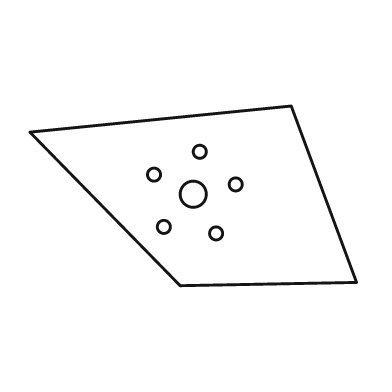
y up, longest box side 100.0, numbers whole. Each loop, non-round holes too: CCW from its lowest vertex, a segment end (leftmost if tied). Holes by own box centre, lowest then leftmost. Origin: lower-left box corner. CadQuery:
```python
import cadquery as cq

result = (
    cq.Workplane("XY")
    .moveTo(46.0, 0.0)
    .lineTo(100.0, 1.0)
    .lineTo(80.0, 55.0)
    .lineTo(0.0, 47.0)
    .close()
    .moveTo(57.0, 16.0)
    .circle(2.0)
    .moveTo(41.0, 18.0)
    .circle(2.0)
    .moveTo(50.0, 28.0)
    .circle(4.0)
    .moveTo(63.0, 31.0)
    .circle(2.0)
    .moveTo(38.0, 34.0)
    .circle(2.0)
    .moveTo(52.0, 41.0)
    .circle(2.0)
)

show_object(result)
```